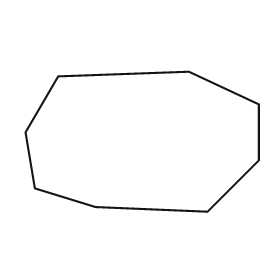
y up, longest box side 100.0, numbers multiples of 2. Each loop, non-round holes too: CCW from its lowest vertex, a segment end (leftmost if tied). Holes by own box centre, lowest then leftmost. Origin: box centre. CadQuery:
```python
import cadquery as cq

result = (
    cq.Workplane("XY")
    .moveTo(28.0, -30.0)
    .lineTo(50.0, -8.0)
    .lineTo(50.0, 16.0)
    .lineTo(20.0, 30.0)
    .lineTo(-36.0, 28.0)
    .lineTo(-50.0, 4.0)
    .lineTo(-46.0, -20.0)
    .lineTo(-20.0, -28.0)
    .close()
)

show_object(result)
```